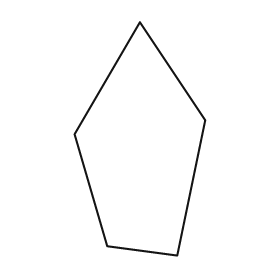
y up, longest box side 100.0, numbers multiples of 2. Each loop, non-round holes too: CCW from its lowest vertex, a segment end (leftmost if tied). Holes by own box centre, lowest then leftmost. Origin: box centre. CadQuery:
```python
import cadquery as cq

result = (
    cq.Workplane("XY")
    .moveTo(16.0, -50.0)
    .lineTo(28.0, 8.0)
    .lineTo(0.0, 50.0)
    .lineTo(-28.0, 2.0)
    .lineTo(-14.0, -46.0)
    .close()
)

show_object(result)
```